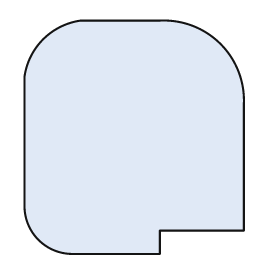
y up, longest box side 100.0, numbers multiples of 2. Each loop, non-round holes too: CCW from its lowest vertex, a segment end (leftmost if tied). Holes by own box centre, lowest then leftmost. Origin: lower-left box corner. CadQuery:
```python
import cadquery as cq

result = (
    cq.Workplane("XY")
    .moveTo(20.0, 0.0)
    .lineTo(58.0, 0.0)
    .lineTo(58.0, 10.0)
    .lineTo(94.0, 10.0)
    .lineTo(94.0, 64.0)
    .threePointArc((84.0, 90.0), (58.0, 100.0))
    .lineTo(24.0, 100.0)
    .threePointArc((8.0, 92.0), (0.0, 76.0))
    .lineTo(0.0, 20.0)
    .threePointArc((6.0, 6.0), (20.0, 0.0))
    .close()
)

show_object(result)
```